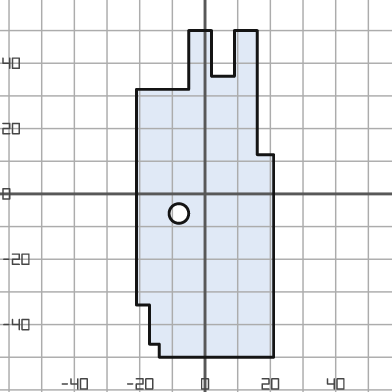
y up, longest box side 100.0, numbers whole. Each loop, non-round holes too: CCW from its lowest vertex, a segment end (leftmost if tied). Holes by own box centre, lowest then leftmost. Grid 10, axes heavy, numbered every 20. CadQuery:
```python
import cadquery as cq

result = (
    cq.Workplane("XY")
    .moveTo(-14.0, -50.0)
    .lineTo(21.0, -50.0)
    .lineTo(21.0, 12.0)
    .lineTo(16.0, 12.0)
    .lineTo(16.0, 50.0)
    .lineTo(9.0, 50.0)
    .lineTo(9.0, 36.0)
    .lineTo(2.0, 36.0)
    .lineTo(2.0, 50.0)
    .lineTo(-5.0, 50.0)
    .lineTo(-5.0, 32.0)
    .lineTo(-21.0, 32.0)
    .lineTo(-21.0, -34.0)
    .lineTo(-17.0, -34.0)
    .lineTo(-17.0, -46.0)
    .lineTo(-14.0, -46.0)
    .close()
    .moveTo(-8.0, -6.0)
    .circle(3.0)
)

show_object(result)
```